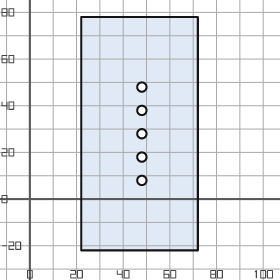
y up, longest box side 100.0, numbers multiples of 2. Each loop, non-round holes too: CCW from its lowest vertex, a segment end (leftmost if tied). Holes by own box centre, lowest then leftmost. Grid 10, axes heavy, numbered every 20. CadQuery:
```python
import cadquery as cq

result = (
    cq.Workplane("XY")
    .moveTo(22.0, -22.0)
    .lineTo(72.0, -22.0)
    .lineTo(72.0, 78.0)
    .lineTo(22.0, 78.0)
    .close()
    .moveTo(48.0, 8.0)
    .circle(2.0)
    .moveTo(48.0, 18.0)
    .circle(2.0)
    .moveTo(48.0, 28.0)
    .circle(2.0)
    .moveTo(48.0, 38.0)
    .circle(2.0)
    .moveTo(48.0, 48.0)
    .circle(2.0)
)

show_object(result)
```